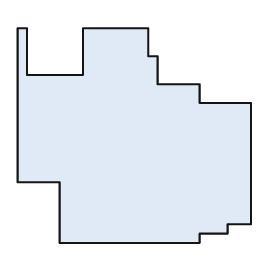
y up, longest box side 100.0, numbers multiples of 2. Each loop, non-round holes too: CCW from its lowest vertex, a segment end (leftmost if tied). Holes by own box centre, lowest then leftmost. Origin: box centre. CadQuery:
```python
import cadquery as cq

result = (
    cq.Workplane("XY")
    .moveTo(-32.0, -46.0)
    .lineTo(28.0, -46.0)
    .lineTo(28.0, -42.0)
    .lineTo(40.0, -42.0)
    .lineTo(40.0, -38.0)
    .lineTo(50.0, -38.0)
    .lineTo(50.0, 14.0)
    .lineTo(28.0, 14.0)
    .lineTo(28.0, 22.0)
    .lineTo(10.0, 22.0)
    .lineTo(10.0, 34.0)
    .lineTo(6.0, 34.0)
    .lineTo(6.0, 46.0)
    .lineTo(-22.0, 46.0)
    .lineTo(-22.0, 26.0)
    .lineTo(-46.0, 26.0)
    .lineTo(-46.0, 46.0)
    .lineTo(-50.0, 46.0)
    .lineTo(-50.0, -20.0)
    .lineTo(-32.0, -20.0)
    .close()
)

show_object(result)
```